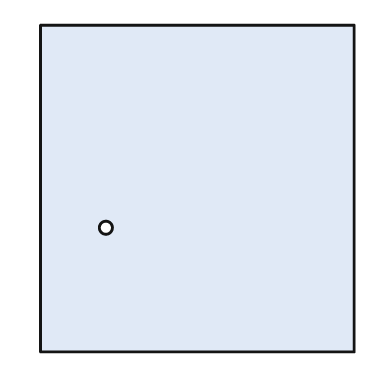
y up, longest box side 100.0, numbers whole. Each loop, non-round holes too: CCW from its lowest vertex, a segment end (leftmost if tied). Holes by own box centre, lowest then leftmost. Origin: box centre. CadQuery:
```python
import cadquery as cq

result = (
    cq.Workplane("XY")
    .moveTo(-48.0, -50.0)
    .lineTo(48.0, -50.0)
    .lineTo(48.0, 50.0)
    .lineTo(-48.0, 50.0)
    .close()
    .moveTo(-28.0, -12.0)
    .circle(2.0)
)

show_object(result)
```